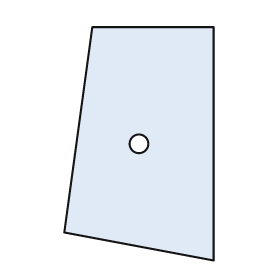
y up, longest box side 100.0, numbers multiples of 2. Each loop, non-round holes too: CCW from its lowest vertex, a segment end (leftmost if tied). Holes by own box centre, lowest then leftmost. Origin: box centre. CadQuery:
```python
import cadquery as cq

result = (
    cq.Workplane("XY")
    .moveTo(32.0, -50.0)
    .lineTo(32.0, 50.0)
    .lineTo(-20.0, 50.0)
    .lineTo(-32.0, -38.0)
    .close()
    .moveTo(0.0, 0.0)
    .circle(4.0)
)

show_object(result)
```